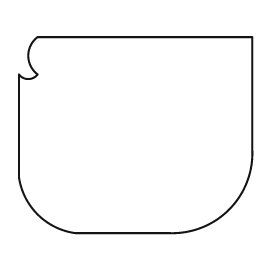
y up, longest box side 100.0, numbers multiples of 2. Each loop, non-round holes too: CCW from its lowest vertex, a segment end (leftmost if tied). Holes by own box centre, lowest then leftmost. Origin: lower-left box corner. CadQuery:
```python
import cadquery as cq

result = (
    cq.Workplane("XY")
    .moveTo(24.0, 0.0)
    .lineTo(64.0, 0.0)
    .threePointArc((90.0, 10.0), (100.0, 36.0))
    .lineTo(100.0, 84.0)
    .lineTo(8.0, 84.0)
    .threePointArc((4.0, 76.0), (8.0, 68.0))
    .threePointArc((4.0, 66.0), (0.0, 68.0))
    .lineTo(0.0, 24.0)
    .threePointArc((8.0, 8.0), (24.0, 0.0))
    .close()
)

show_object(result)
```